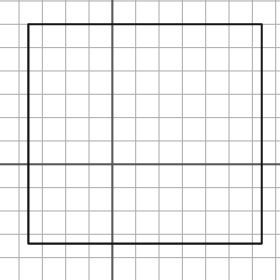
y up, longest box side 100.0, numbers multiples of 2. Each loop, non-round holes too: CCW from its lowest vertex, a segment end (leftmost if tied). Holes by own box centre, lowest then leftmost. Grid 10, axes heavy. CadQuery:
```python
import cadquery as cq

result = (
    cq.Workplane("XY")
    .moveTo(-36.0, -34.0)
    .lineTo(64.0, -34.0)
    .lineTo(64.0, 60.0)
    .lineTo(-36.0, 60.0)
    .close()
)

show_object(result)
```